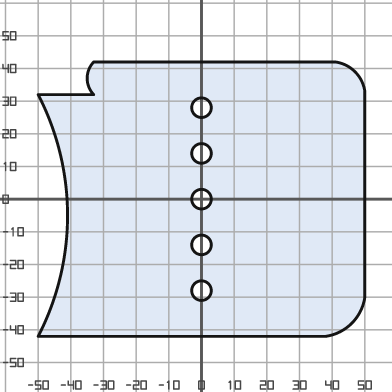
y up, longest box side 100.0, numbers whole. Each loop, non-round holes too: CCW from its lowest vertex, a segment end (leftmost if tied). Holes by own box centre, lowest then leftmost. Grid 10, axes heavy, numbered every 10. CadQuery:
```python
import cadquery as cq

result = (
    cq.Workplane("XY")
    .moveTo(-50.0, -42.0)
    .lineTo(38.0, -42.0)
    .threePointArc((46.0, -38.0), (50.0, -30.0))
    .lineTo(50.0, 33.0)
    .threePointArc((47.0, 39.0), (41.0, 42.0))
    .lineTo(-33.0, 42.0)
    .threePointArc((-35.0, 37.0), (-33.0, 32.0))
    .lineTo(-50.0, 32.0)
    .threePointArc((-41.0, -5.0), (-50.0, -42.0))
    .close()
    .moveTo(0.0, -28.0)
    .circle(3.0)
    .moveTo(0.0, -14.0)
    .circle(3.0)
    .moveTo(0.0, 0.0)
    .circle(3.0)
    .moveTo(0.0, 14.0)
    .circle(3.0)
    .moveTo(0.0, 28.0)
    .circle(3.0)
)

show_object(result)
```